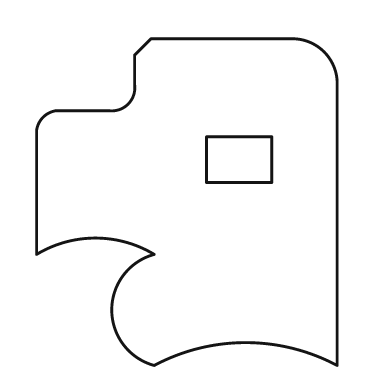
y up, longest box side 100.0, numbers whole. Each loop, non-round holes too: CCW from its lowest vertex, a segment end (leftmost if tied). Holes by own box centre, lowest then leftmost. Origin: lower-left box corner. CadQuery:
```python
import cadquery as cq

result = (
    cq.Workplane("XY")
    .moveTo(36.0, 0.0)
    .threePointArc((64.0, 7.0), (92.0, 0.0))
    .lineTo(92.0, 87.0)
    .threePointArc((88.0, 96.0), (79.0, 100.0))
    .lineTo(35.0, 100.0)
    .lineTo(30.0, 95.0)
    .lineTo(30.0, 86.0)
    .threePointArc((28.0, 80.0), (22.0, 78.0))
    .lineTo(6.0, 78.0)
    .threePointArc((2.0, 76.0), (0.0, 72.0))
    .lineTo(0.0, 34.0)
    .threePointArc((18.0, 39.0), (36.0, 34.0))
    .threePointArc((23.0, 17.0), (36.0, 0.0))
    .close()
    .moveTo(52.0, 56.0)
    .lineTo(72.0, 56.0)
    .lineTo(72.0, 70.0)
    .lineTo(52.0, 70.0)
    .close()
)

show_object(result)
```